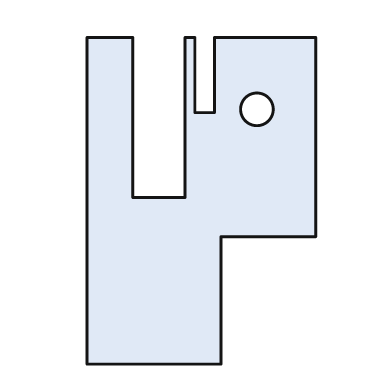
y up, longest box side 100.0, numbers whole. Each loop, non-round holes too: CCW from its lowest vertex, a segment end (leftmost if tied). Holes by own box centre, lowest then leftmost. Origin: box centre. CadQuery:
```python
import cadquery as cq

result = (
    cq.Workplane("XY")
    .moveTo(-35.0, -50.0)
    .lineTo(6.0, -50.0)
    .lineTo(6.0, -11.0)
    .lineTo(35.0, -11.0)
    .lineTo(35.0, 50.0)
    .lineTo(4.0, 50.0)
    .lineTo(4.0, 27.0)
    .lineTo(-2.0, 27.0)
    .lineTo(-2.0, 50.0)
    .lineTo(-5.0, 50.0)
    .lineTo(-5.0, 1.0)
    .lineTo(-21.0, 1.0)
    .lineTo(-21.0, 50.0)
    .lineTo(-35.0, 50.0)
    .close()
    .moveTo(17.0, 28.0)
    .circle(5.0)
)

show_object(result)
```